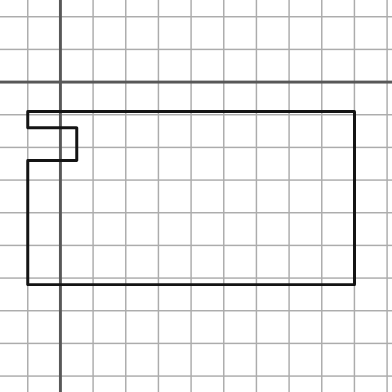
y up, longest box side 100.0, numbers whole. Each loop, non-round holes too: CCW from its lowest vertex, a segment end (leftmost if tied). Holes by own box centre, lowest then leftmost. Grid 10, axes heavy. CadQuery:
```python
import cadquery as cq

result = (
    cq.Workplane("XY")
    .moveTo(-10.0, -62.0)
    .lineTo(90.0, -62.0)
    .lineTo(90.0, -9.0)
    .lineTo(-10.0, -9.0)
    .lineTo(-10.0, -14.0)
    .lineTo(5.0, -14.0)
    .lineTo(5.0, -24.0)
    .lineTo(-10.0, -24.0)
    .close()
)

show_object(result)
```